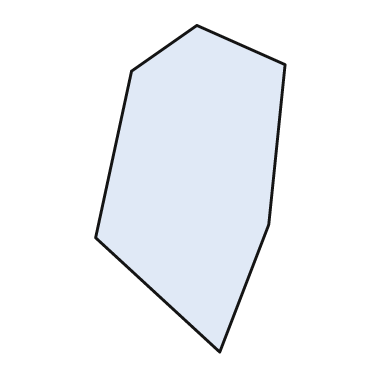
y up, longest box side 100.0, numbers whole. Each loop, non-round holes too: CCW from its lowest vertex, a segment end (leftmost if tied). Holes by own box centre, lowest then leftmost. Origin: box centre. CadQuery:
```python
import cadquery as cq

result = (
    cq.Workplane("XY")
    .moveTo(9.0, -50.0)
    .lineTo(24.0, -11.0)
    .lineTo(29.0, 38.0)
    .lineTo(2.0, 50.0)
    .lineTo(-18.0, 36.0)
    .lineTo(-29.0, -15.0)
    .close()
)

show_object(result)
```